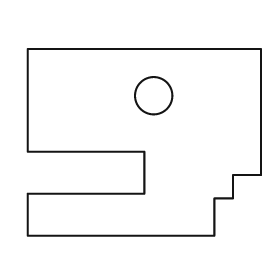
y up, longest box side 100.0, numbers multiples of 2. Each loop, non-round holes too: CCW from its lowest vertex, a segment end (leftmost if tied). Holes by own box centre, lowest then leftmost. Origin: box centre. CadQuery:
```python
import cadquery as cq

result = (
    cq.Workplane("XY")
    .moveTo(-50.0, -40.0)
    .lineTo(30.0, -40.0)
    .lineTo(30.0, -24.0)
    .lineTo(38.0, -24.0)
    .lineTo(38.0, -14.0)
    .lineTo(50.0, -14.0)
    .lineTo(50.0, 40.0)
    .lineTo(-50.0, 40.0)
    .lineTo(-50.0, -4.0)
    .lineTo(0.0, -4.0)
    .lineTo(0.0, -22.0)
    .lineTo(-50.0, -22.0)
    .close()
    .moveTo(4.0, 20.0)
    .circle(8.0)
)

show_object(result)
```